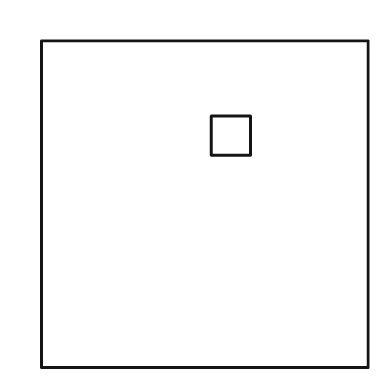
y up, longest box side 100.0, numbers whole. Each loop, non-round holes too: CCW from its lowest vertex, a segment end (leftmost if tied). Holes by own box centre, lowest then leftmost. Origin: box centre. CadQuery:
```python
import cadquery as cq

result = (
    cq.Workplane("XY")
    .moveTo(-50.0, -50.0)
    .lineTo(50.0, -50.0)
    .lineTo(50.0, 50.0)
    .lineTo(-50.0, 50.0)
    .close()
    .moveTo(2.0, 15.0)
    .lineTo(14.0, 15.0)
    .lineTo(14.0, 27.0)
    .lineTo(2.0, 27.0)
    .close()
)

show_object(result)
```